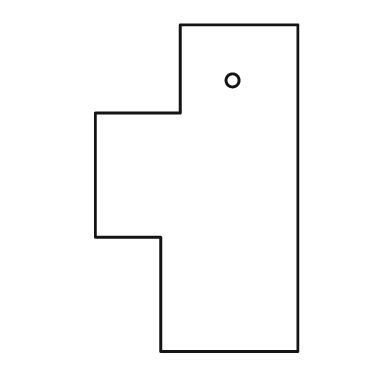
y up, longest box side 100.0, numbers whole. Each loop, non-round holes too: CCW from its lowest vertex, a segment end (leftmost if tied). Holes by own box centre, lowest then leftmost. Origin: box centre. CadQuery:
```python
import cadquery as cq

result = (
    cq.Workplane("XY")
    .moveTo(-11.0, -50.0)
    .lineTo(31.0, -50.0)
    .lineTo(31.0, 50.0)
    .lineTo(-5.0, 50.0)
    .lineTo(-5.0, 23.0)
    .lineTo(-31.0, 23.0)
    .lineTo(-31.0, -15.0)
    .lineTo(-11.0, -15.0)
    .close()
    .moveTo(11.0, 33.0)
    .circle(2.0)
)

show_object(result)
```